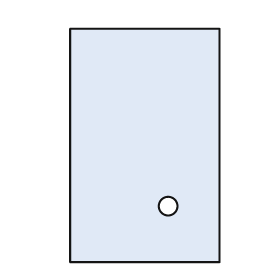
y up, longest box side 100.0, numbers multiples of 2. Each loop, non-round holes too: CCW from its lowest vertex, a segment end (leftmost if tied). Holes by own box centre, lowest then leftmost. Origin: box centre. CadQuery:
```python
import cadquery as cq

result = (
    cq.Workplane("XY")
    .moveTo(-32.0, -50.0)
    .lineTo(32.0, -50.0)
    .lineTo(32.0, 50.0)
    .lineTo(-32.0, 50.0)
    .close()
    .moveTo(10.0, -26.0)
    .circle(4.0)
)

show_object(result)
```